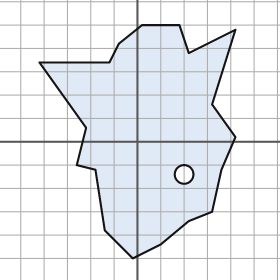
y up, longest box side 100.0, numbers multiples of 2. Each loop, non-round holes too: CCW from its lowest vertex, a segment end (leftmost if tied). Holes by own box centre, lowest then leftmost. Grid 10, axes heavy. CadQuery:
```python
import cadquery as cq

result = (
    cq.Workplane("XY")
    .moveTo(-2.0, -50.0)
    .lineTo(10.0, -44.0)
    .lineTo(22.0, -34.0)
    .lineTo(32.0, -30.0)
    .lineTo(36.0, -12.0)
    .lineTo(42.0, 2.0)
    .lineTo(32.0, 16.0)
    .lineTo(42.0, 48.0)
    .lineTo(22.0, 38.0)
    .lineTo(18.0, 50.0)
    .lineTo(2.0, 50.0)
    .lineTo(-8.0, 42.0)
    .lineTo(-12.0, 34.0)
    .lineTo(-42.0, 34.0)
    .lineTo(-22.0, 6.0)
    .lineTo(-26.0, -10.0)
    .lineTo(-18.0, -12.0)
    .lineTo(-14.0, -38.0)
    .close()
    .moveTo(20.0, -14.0)
    .circle(4.0)
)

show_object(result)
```